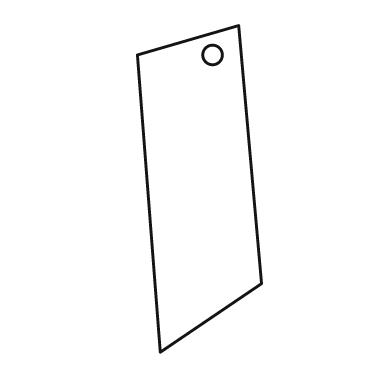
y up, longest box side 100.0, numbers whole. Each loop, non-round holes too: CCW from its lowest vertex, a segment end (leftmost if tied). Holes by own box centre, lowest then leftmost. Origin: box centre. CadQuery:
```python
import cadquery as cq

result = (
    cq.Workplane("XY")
    .moveTo(-12.0, -50.0)
    .lineTo(19.0, -29.0)
    .lineTo(12.0, 50.0)
    .lineTo(-19.0, 41.0)
    .close()
    .moveTo(4.0, 41.0)
    .circle(3.0)
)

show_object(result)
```